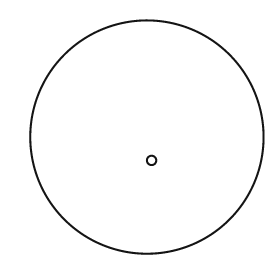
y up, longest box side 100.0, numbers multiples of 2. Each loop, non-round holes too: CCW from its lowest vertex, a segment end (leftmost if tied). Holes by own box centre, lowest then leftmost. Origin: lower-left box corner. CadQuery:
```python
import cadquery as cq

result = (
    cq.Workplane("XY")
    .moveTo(50.0, 50.0)
    .circle(50.0)
    .moveTo(52.0, 40.0)
    .circle(2.0)
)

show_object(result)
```